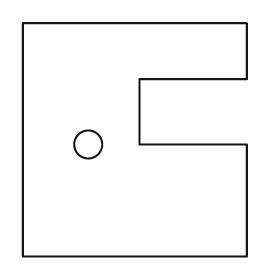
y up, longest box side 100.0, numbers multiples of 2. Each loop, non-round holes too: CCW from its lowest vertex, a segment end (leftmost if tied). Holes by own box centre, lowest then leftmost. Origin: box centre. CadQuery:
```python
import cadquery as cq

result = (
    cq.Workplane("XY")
    .moveTo(-48.0, -50.0)
    .lineTo(48.0, -50.0)
    .lineTo(48.0, -2.0)
    .lineTo(2.0, -2.0)
    .lineTo(2.0, 26.0)
    .lineTo(48.0, 26.0)
    .lineTo(48.0, 50.0)
    .lineTo(-48.0, 50.0)
    .close()
    .moveTo(-20.0, -2.0)
    .circle(6.0)
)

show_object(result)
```